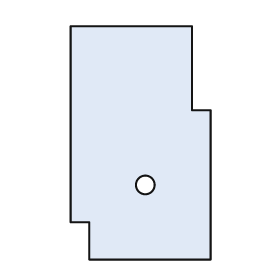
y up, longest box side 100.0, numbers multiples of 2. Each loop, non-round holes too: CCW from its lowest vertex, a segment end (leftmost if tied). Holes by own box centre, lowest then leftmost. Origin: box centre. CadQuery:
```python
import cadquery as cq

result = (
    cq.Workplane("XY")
    .moveTo(-22.0, -50.0)
    .lineTo(30.0, -50.0)
    .lineTo(30.0, 14.0)
    .lineTo(22.0, 14.0)
    .lineTo(22.0, 50.0)
    .lineTo(-30.0, 50.0)
    .lineTo(-30.0, -34.0)
    .lineTo(-22.0, -34.0)
    .close()
    .moveTo(2.0, -18.0)
    .circle(4.0)
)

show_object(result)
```